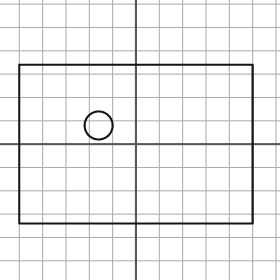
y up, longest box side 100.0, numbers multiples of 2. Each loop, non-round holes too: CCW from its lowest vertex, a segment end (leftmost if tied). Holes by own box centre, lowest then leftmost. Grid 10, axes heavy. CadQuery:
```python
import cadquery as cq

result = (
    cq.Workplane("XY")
    .moveTo(-50.0, -34.0)
    .lineTo(50.0, -34.0)
    .lineTo(50.0, 34.0)
    .lineTo(-50.0, 34.0)
    .close()
    .moveTo(-16.0, 8.0)
    .circle(6.0)
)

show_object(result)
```